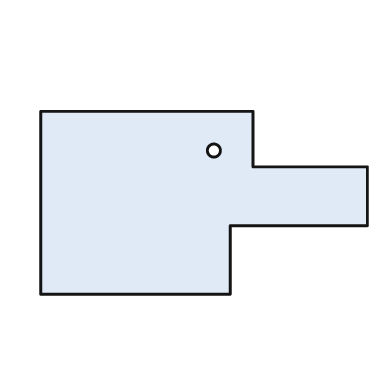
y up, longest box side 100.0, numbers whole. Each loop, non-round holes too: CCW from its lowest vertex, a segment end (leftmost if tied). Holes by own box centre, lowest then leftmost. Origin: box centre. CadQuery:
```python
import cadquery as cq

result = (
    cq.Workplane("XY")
    .moveTo(-50.0, -28.0)
    .lineTo(8.0, -28.0)
    .lineTo(8.0, -7.0)
    .lineTo(50.0, -7.0)
    .lineTo(50.0, 11.0)
    .lineTo(15.0, 11.0)
    .lineTo(15.0, 28.0)
    .lineTo(-50.0, 28.0)
    .close()
    .moveTo(3.0, 16.0)
    .circle(2.0)
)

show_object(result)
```